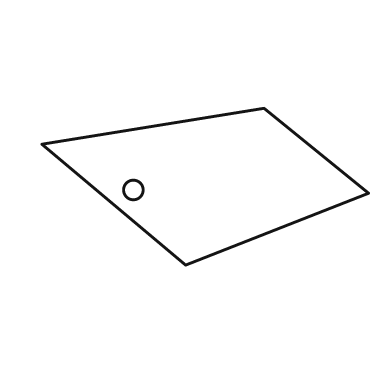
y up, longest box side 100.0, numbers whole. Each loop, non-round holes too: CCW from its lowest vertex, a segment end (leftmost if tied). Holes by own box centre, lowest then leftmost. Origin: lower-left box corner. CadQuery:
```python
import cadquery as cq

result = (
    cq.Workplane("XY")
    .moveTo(44.0, 0.0)
    .lineTo(100.0, 22.0)
    .lineTo(68.0, 48.0)
    .lineTo(0.0, 37.0)
    .close()
    .moveTo(28.0, 23.0)
    .circle(3.0)
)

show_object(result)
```